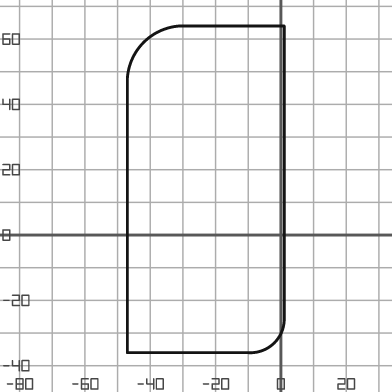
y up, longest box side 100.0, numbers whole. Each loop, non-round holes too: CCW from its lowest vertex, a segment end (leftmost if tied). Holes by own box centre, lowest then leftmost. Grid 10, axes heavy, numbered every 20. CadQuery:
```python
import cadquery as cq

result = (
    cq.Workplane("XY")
    .moveTo(-47.0, -36.0)
    .lineTo(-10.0, -36.0)
    .threePointArc((-2.0, -33.0), (1.0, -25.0))
    .lineTo(1.0, 64.0)
    .lineTo(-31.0, 64.0)
    .threePointArc((-42.0, 59.0), (-47.0, 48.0))
    .close()
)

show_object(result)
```